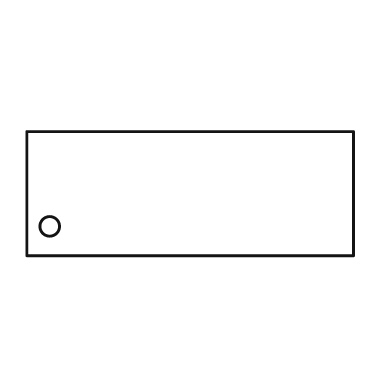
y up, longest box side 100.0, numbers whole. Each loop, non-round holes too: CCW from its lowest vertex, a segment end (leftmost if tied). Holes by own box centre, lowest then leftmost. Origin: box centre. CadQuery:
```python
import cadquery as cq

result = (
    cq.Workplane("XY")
    .moveTo(-50.0, -19.0)
    .lineTo(50.0, -19.0)
    .lineTo(50.0, 19.0)
    .lineTo(-50.0, 19.0)
    .close()
    .moveTo(-43.0, -10.0)
    .circle(3.0)
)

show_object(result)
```